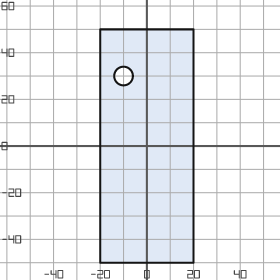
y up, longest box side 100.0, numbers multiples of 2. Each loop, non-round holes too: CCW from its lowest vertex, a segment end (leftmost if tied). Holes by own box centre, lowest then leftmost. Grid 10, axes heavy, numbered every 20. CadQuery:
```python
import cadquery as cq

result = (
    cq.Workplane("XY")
    .moveTo(-20.0, -50.0)
    .lineTo(20.0, -50.0)
    .lineTo(20.0, 50.0)
    .lineTo(-20.0, 50.0)
    .close()
    .moveTo(-10.0, 30.0)
    .circle(4.0)
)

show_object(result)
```